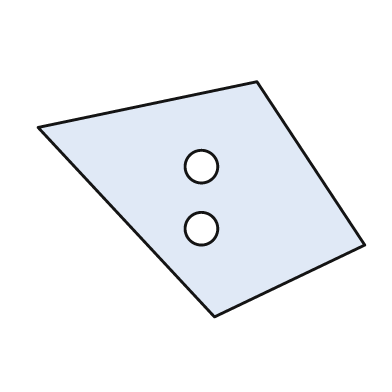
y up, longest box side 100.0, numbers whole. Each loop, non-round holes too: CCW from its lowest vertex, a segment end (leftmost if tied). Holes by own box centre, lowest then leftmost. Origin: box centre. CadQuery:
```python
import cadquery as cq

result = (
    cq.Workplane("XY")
    .moveTo(4.0, -36.0)
    .lineTo(50.0, -14.0)
    .lineTo(17.0, 36.0)
    .lineTo(-50.0, 22.0)
    .close()
    .moveTo(0.0, -9.0)
    .circle(5.0)
    .moveTo(0.0, 10.0)
    .circle(5.0)
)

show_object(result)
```